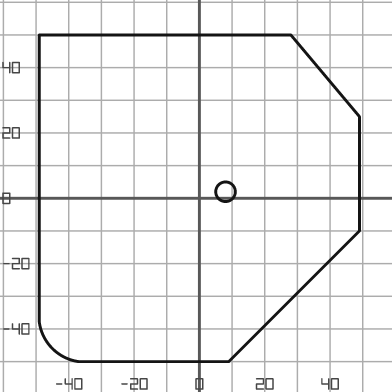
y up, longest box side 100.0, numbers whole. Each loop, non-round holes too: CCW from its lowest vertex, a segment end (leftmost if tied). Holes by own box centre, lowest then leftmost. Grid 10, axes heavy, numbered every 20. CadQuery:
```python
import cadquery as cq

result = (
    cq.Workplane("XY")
    .moveTo(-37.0, -50.0)
    .lineTo(9.0, -50.0)
    .lineTo(49.0, -10.0)
    .lineTo(49.0, 25.0)
    .lineTo(28.0, 50.0)
    .lineTo(-49.0, 50.0)
    .lineTo(-49.0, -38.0)
    .threePointArc((-45.0, -46.0), (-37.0, -50.0))
    .close()
    .moveTo(8.0, 2.0)
    .circle(3.0)
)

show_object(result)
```